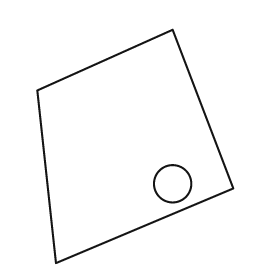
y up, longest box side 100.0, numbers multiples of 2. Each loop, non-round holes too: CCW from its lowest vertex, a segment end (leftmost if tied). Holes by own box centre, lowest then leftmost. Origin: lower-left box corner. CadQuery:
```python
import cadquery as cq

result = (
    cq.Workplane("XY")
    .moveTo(8.0, 0.0)
    .lineTo(84.0, 32.0)
    .lineTo(58.0, 100.0)
    .lineTo(0.0, 74.0)
    .close()
    .moveTo(58.0, 34.0)
    .circle(8.0)
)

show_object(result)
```